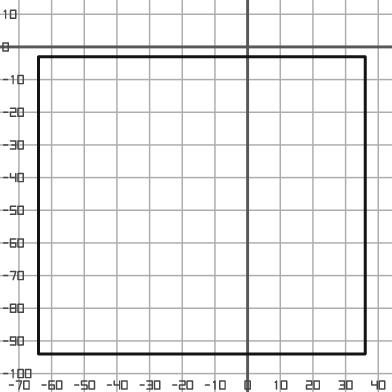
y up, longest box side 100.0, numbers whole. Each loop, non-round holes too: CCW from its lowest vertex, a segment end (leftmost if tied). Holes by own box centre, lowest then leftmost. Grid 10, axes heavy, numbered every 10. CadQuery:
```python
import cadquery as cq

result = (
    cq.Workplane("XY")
    .moveTo(-64.0, -94.0)
    .lineTo(36.0, -94.0)
    .lineTo(36.0, -3.0)
    .lineTo(-64.0, -3.0)
    .close()
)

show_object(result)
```